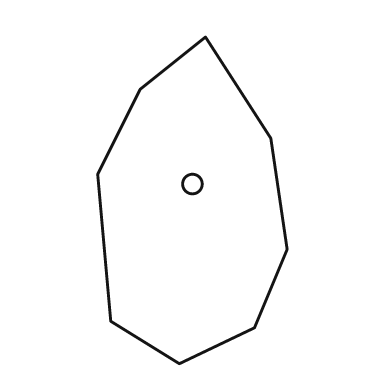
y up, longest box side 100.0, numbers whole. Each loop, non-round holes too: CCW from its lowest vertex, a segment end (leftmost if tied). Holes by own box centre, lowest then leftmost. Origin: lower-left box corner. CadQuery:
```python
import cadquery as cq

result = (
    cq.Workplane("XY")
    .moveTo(25.0, 0.0)
    .lineTo(48.0, 11.0)
    .lineTo(58.0, 35.0)
    .lineTo(53.0, 69.0)
    .lineTo(33.0, 100.0)
    .lineTo(13.0, 84.0)
    .lineTo(0.0, 58.0)
    .lineTo(4.0, 13.0)
    .close()
    .moveTo(29.0, 55.0)
    .circle(3.0)
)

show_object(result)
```